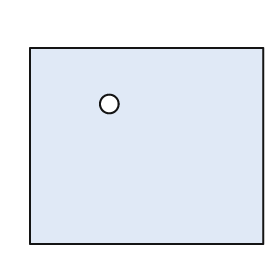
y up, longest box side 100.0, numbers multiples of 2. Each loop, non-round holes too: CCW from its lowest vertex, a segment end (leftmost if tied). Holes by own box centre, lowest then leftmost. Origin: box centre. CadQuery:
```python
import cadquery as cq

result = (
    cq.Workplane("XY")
    .moveTo(-50.0, -42.0)
    .lineTo(50.0, -42.0)
    .lineTo(50.0, 42.0)
    .lineTo(-50.0, 42.0)
    .close()
    .moveTo(-16.0, 18.0)
    .circle(4.0)
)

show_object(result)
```